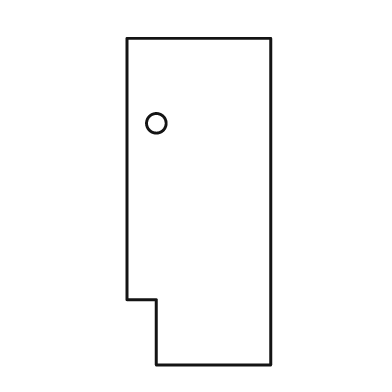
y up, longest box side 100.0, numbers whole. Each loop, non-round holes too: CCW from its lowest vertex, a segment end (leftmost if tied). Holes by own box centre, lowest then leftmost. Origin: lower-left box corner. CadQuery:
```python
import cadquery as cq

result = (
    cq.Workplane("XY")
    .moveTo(9.0, 0.0)
    .lineTo(44.0, 0.0)
    .lineTo(44.0, 100.0)
    .lineTo(0.0, 100.0)
    .lineTo(0.0, 20.0)
    .lineTo(9.0, 20.0)
    .close()
    .moveTo(9.0, 74.0)
    .circle(3.0)
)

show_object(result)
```